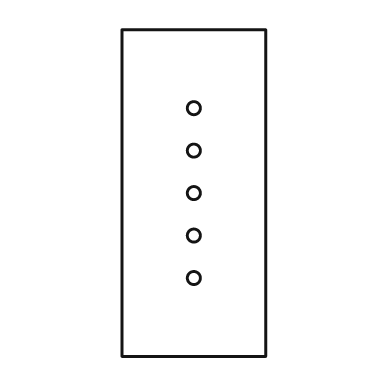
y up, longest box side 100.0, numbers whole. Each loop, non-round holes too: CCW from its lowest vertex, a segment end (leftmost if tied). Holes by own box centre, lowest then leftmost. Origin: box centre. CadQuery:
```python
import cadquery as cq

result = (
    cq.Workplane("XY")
    .moveTo(-22.0, -50.0)
    .lineTo(22.0, -50.0)
    .lineTo(22.0, 50.0)
    .lineTo(-22.0, 50.0)
    .close()
    .moveTo(0.0, -26.0)
    .circle(2.0)
    .moveTo(0.0, -13.0)
    .circle(2.0)
    .moveTo(0.0, 0.0)
    .circle(2.0)
    .moveTo(0.0, 13.0)
    .circle(2.0)
    .moveTo(0.0, 26.0)
    .circle(2.0)
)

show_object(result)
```